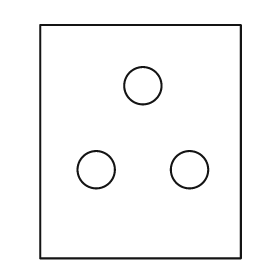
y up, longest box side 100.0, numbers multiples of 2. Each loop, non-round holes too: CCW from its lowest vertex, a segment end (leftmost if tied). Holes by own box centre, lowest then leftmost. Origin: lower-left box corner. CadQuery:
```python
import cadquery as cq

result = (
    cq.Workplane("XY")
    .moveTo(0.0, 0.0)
    .lineTo(86.0, 0.0)
    .lineTo(86.0, 100.0)
    .lineTo(0.0, 100.0)
    .close()
    .moveTo(24.0, 38.0)
    .circle(8.0)
    .moveTo(64.0, 38.0)
    .circle(8.0)
    .moveTo(44.0, 74.0)
    .circle(8.0)
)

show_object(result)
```